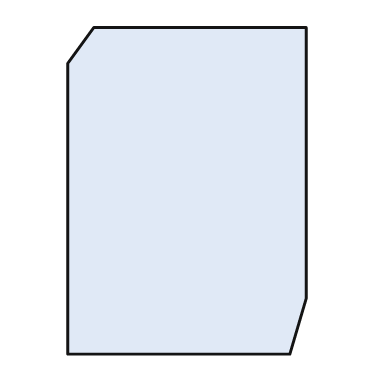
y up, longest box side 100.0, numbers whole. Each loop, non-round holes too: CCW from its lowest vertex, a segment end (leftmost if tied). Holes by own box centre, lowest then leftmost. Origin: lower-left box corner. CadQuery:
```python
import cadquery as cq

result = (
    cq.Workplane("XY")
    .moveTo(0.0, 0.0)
    .lineTo(68.0, 0.0)
    .lineTo(73.0, 17.0)
    .lineTo(73.0, 100.0)
    .lineTo(8.0, 100.0)
    .lineTo(0.0, 89.0)
    .close()
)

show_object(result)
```